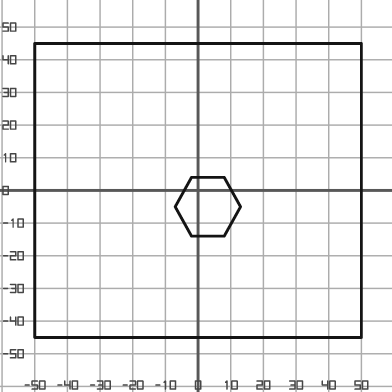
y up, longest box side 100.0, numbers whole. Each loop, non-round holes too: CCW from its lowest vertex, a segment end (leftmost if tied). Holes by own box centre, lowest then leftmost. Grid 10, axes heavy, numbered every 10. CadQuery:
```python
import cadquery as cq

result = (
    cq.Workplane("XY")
    .moveTo(-50.0, -45.0)
    .lineTo(50.0, -45.0)
    .lineTo(50.0, 45.0)
    .lineTo(-50.0, 45.0)
    .close()
    .moveTo(-2.0, -14.0)
    .lineTo(8.0, -14.0)
    .lineTo(13.0, -5.0)
    .lineTo(8.0, 4.0)
    .lineTo(-2.0, 4.0)
    .lineTo(-7.0, -5.0)
    .close()
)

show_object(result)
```